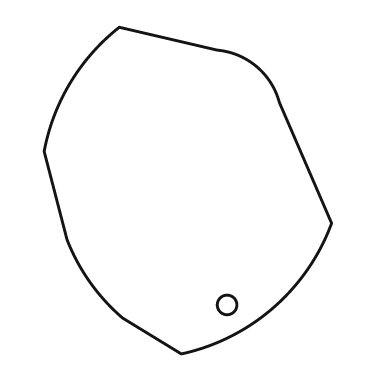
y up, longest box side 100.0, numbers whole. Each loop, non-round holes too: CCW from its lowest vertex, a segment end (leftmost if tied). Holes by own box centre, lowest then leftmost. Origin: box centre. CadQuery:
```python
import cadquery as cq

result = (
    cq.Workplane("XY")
    .moveTo(-2.0, -50.0)
    .threePointArc((26.0, -36.0), (44.0, -10.0))
    .lineTo(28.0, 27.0)
    .threePointArc((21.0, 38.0), (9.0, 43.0))
    .lineTo(-21.0, 50.0)
    .threePointArc((-36.0, 33.0), (-44.0, 12.0))
    .lineTo(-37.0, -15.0)
    .threePointArc((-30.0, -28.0), (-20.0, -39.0))
    .close()
    .moveTo(12.0, -35.0)
    .circle(3.0)
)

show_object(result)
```